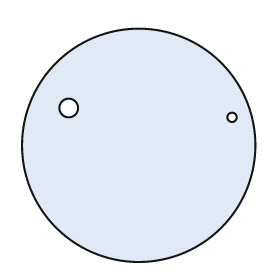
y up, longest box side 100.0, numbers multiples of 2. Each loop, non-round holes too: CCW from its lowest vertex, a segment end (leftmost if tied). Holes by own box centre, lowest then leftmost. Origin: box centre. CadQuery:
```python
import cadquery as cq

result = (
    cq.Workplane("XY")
    .moveTo(0.0, 0.0)
    .circle(50.0)
    .moveTo(40.0, 12.0)
    .circle(2.0)
    .moveTo(-30.0, 16.0)
    .circle(4.0)
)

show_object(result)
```